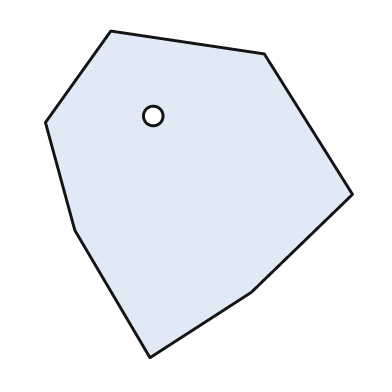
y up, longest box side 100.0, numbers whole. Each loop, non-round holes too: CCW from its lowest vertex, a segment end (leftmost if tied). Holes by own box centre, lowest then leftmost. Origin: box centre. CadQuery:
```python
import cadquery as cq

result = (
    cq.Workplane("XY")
    .moveTo(-15.0, -50.0)
    .lineTo(16.0, -30.0)
    .lineTo(47.0, 0.0)
    .lineTo(20.0, 43.0)
    .lineTo(-27.0, 50.0)
    .lineTo(-47.0, 22.0)
    .lineTo(-38.0, -11.0)
    .close()
    .moveTo(-14.0, 24.0)
    .circle(3.0)
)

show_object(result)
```